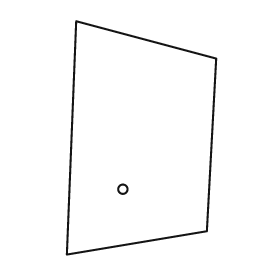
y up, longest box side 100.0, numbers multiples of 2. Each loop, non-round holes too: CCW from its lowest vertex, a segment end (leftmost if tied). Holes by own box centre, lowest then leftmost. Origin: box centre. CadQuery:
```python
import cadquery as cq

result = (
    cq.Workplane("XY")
    .moveTo(-32.0, -50.0)
    .lineTo(28.0, -40.0)
    .lineTo(32.0, 34.0)
    .lineTo(-28.0, 50.0)
    .close()
    .moveTo(-8.0, -22.0)
    .circle(2.0)
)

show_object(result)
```